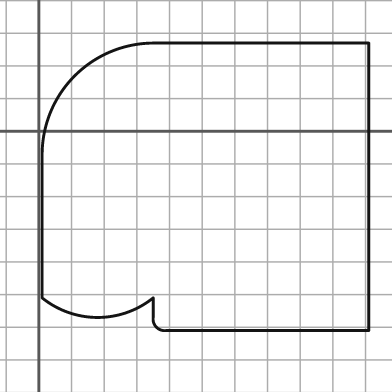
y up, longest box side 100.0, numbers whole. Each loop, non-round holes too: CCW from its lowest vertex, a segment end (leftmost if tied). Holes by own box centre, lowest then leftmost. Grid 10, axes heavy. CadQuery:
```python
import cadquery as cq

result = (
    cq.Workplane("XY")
    .moveTo(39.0, -61.0)
    .lineTo(101.0, -61.0)
    .lineTo(101.0, 27.0)
    .lineTo(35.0, 27.0)
    .threePointArc((11.0, 17.0), (1.0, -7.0))
    .lineTo(1.0, -51.0)
    .threePointArc((18.0, -57.0), (35.0, -51.0))
    .lineTo(35.0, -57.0)
    .threePointArc((36.0, -60.0), (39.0, -61.0))
    .close()
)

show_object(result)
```